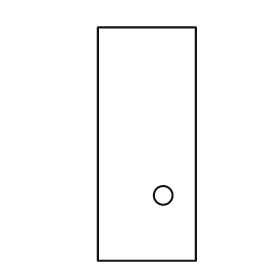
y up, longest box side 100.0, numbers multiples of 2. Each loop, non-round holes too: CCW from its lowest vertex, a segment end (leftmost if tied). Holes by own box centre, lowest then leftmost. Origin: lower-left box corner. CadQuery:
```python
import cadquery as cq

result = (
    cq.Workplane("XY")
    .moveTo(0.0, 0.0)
    .lineTo(42.0, 0.0)
    .lineTo(42.0, 100.0)
    .lineTo(0.0, 100.0)
    .close()
    .moveTo(28.0, 28.0)
    .circle(4.0)
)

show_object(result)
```